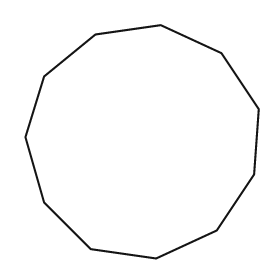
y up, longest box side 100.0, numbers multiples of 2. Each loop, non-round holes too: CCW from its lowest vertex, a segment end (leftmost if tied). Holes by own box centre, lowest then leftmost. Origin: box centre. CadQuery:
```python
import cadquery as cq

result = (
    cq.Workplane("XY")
    .moveTo(6.0, -50.0)
    .lineTo(32.0, -38.0)
    .lineTo(48.0, -14.0)
    .lineTo(50.0, 14.0)
    .lineTo(34.0, 38.0)
    .lineTo(8.0, 50.0)
    .lineTo(-20.0, 46.0)
    .lineTo(-42.0, 28.0)
    .lineTo(-50.0, 2.0)
    .lineTo(-42.0, -26.0)
    .lineTo(-22.0, -46.0)
    .close()
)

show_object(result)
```